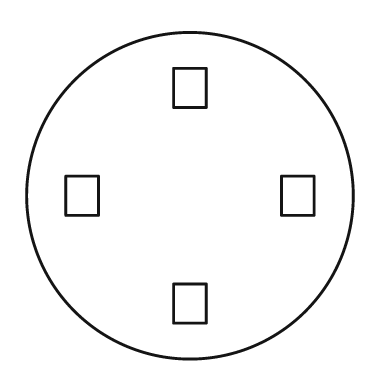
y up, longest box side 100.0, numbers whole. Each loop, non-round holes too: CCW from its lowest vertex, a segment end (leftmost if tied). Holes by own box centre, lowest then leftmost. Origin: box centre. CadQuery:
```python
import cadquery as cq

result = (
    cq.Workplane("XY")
    .moveTo(0.0, 0.0)
    .circle(50.0)
    .moveTo(-5.0, -39.0)
    .lineTo(5.0, -39.0)
    .lineTo(5.0, -27.0)
    .lineTo(-5.0, -27.0)
    .close()
    .moveTo(-38.0, -6.0)
    .lineTo(-28.0, -6.0)
    .lineTo(-28.0, 6.0)
    .lineTo(-38.0, 6.0)
    .close()
    .moveTo(28.0, -6.0)
    .lineTo(38.0, -6.0)
    .lineTo(38.0, 6.0)
    .lineTo(28.0, 6.0)
    .close()
    .moveTo(-5.0, 27.0)
    .lineTo(5.0, 27.0)
    .lineTo(5.0, 39.0)
    .lineTo(-5.0, 39.0)
    .close()
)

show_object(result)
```